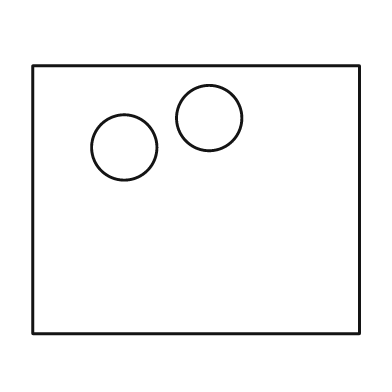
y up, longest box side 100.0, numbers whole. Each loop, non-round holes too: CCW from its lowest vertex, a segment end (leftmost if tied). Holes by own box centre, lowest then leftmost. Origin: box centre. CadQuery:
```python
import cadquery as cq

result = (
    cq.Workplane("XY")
    .moveTo(-50.0, -41.0)
    .lineTo(50.0, -41.0)
    .lineTo(50.0, 41.0)
    .lineTo(-50.0, 41.0)
    .close()
    .moveTo(-22.0, 16.0)
    .circle(10.0)
    .moveTo(4.0, 25.0)
    .circle(10.0)
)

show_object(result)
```